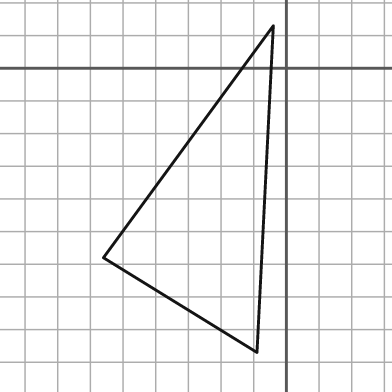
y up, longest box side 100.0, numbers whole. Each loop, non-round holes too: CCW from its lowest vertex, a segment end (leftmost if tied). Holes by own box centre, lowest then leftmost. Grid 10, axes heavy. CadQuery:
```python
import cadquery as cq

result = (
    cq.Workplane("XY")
    .moveTo(-9.0, -87.0)
    .lineTo(-4.0, 13.0)
    .lineTo(-56.0, -58.0)
    .close()
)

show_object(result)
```